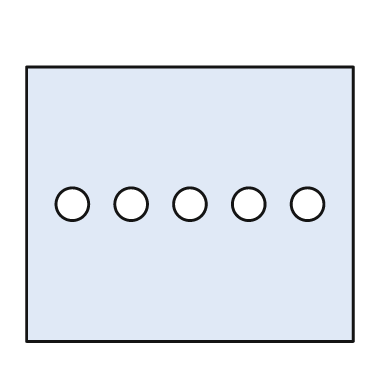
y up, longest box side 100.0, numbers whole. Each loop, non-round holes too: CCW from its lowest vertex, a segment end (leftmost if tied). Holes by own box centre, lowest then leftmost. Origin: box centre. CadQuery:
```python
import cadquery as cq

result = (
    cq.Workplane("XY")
    .moveTo(-50.0, -42.0)
    .lineTo(50.0, -42.0)
    .lineTo(50.0, 42.0)
    .lineTo(-50.0, 42.0)
    .close()
    .moveTo(-36.0, 0.0)
    .circle(5.0)
    .moveTo(-18.0, 0.0)
    .circle(5.0)
    .moveTo(0.0, 0.0)
    .circle(5.0)
    .moveTo(18.0, 0.0)
    .circle(5.0)
    .moveTo(36.0, 0.0)
    .circle(5.0)
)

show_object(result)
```